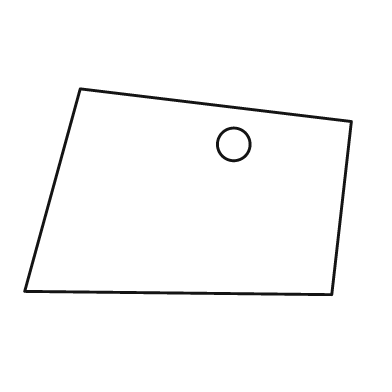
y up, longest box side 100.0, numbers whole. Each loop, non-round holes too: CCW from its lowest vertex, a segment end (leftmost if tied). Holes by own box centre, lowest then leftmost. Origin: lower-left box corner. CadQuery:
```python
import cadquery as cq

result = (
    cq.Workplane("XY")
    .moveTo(94.0, 0.0)
    .lineTo(100.0, 53.0)
    .lineTo(17.0, 63.0)
    .lineTo(0.0, 1.0)
    .close()
    .moveTo(64.0, 46.0)
    .circle(5.0)
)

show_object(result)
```